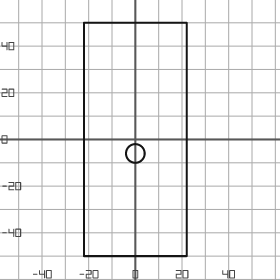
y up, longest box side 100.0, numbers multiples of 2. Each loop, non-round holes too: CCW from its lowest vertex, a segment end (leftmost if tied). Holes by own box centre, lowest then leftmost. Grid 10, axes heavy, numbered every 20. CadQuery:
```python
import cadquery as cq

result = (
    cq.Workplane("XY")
    .moveTo(-22.0, -50.0)
    .lineTo(22.0, -50.0)
    .lineTo(22.0, 50.0)
    .lineTo(-22.0, 50.0)
    .close()
    .moveTo(0.0, -6.0)
    .circle(4.0)
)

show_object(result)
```